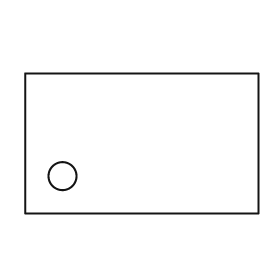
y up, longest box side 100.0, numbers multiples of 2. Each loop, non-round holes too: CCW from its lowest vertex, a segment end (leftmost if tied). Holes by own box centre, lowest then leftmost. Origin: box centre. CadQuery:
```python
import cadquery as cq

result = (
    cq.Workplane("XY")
    .moveTo(-50.0, -30.0)
    .lineTo(50.0, -30.0)
    .lineTo(50.0, 30.0)
    .lineTo(-50.0, 30.0)
    .close()
    .moveTo(-34.0, -14.0)
    .circle(6.0)
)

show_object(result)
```